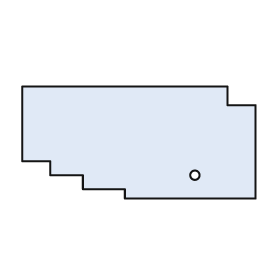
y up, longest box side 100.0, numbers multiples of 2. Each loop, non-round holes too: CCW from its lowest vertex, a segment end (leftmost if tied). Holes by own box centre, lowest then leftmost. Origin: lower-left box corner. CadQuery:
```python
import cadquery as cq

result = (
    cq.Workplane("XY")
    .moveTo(44.0, 0.0)
    .lineTo(100.0, 0.0)
    .lineTo(100.0, 40.0)
    .lineTo(88.0, 40.0)
    .lineTo(88.0, 48.0)
    .lineTo(0.0, 48.0)
    .lineTo(0.0, 16.0)
    .lineTo(12.0, 16.0)
    .lineTo(12.0, 10.0)
    .lineTo(26.0, 10.0)
    .lineTo(26.0, 4.0)
    .lineTo(44.0, 4.0)
    .close()
    .moveTo(74.0, 10.0)
    .circle(2.0)
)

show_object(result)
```